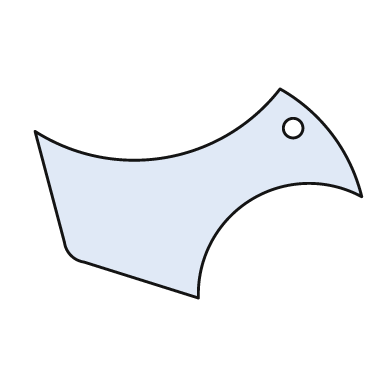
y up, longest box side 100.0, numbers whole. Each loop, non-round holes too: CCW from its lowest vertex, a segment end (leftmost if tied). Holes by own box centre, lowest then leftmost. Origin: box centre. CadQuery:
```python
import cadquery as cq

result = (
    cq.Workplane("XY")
    .moveTo(0.0, -32.0)
    .threePointArc((16.0, -2.0), (50.0, -1.0))
    .threePointArc((41.0, 18.0), (25.0, 32.0))
    .threePointArc((-10.0, 11.0), (-50.0, 19.0))
    .lineTo(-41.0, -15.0)
    .threePointArc((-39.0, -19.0), (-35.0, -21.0))
    .close()
    .moveTo(29.0, 20.0)
    .circle(3.0)
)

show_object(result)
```